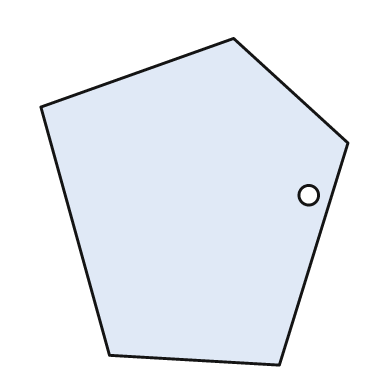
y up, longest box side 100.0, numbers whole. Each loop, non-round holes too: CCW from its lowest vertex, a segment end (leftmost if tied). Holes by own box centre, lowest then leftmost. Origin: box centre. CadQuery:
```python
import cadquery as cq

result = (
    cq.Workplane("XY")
    .moveTo(26.0, -50.0)
    .lineTo(47.0, 18.0)
    .lineTo(12.0, 50.0)
    .lineTo(-47.0, 29.0)
    .lineTo(-26.0, -47.0)
    .close()
    .moveTo(35.0, 2.0)
    .circle(3.0)
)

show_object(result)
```